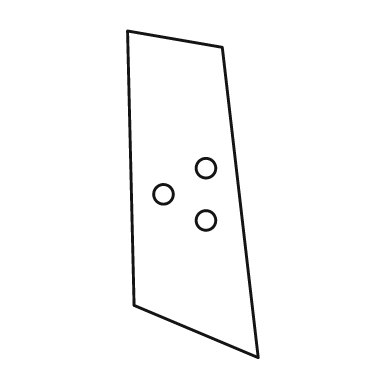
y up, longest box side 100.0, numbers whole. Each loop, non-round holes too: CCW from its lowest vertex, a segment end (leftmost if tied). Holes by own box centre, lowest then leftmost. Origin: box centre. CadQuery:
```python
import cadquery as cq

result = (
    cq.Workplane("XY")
    .moveTo(20.0, -50.0)
    .lineTo(9.0, 45.0)
    .lineTo(-20.0, 50.0)
    .lineTo(-18.0, -34.0)
    .close()
    .moveTo(4.0, -8.0)
    .circle(3.0)
    .moveTo(-9.0, 0.0)
    .circle(3.0)
    .moveTo(4.0, 8.0)
    .circle(3.0)
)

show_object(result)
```